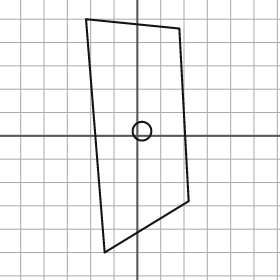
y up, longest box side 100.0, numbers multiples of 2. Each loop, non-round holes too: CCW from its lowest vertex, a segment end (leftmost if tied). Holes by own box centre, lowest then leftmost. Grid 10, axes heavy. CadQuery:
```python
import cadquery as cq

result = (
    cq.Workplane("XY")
    .moveTo(-14.0, -50.0)
    .lineTo(22.0, -28.0)
    .lineTo(18.0, 46.0)
    .lineTo(-22.0, 50.0)
    .close()
    .moveTo(2.0, 2.0)
    .circle(4.0)
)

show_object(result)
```